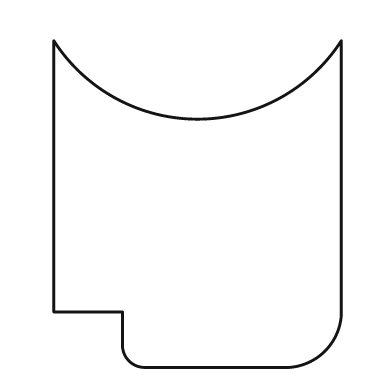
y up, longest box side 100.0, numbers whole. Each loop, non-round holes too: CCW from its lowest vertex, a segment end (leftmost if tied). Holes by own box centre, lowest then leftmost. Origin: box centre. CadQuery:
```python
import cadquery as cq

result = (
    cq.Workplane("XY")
    .moveTo(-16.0, -50.0)
    .lineTo(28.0, -50.0)
    .threePointArc((39.0, -45.0), (44.0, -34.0))
    .lineTo(44.0, 50.0)
    .threePointArc((0.0, 26.0), (-44.0, 50.0))
    .lineTo(-44.0, -33.0)
    .lineTo(-23.0, -33.0)
    .lineTo(-23.0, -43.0)
    .threePointArc((-21.0, -48.0), (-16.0, -50.0))
    .close()
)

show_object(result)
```